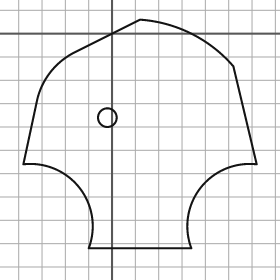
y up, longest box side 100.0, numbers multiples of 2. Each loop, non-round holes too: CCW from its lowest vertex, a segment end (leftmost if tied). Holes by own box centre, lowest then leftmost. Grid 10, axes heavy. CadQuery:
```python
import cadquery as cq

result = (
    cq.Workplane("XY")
    .moveTo(-10.0, -92.0)
    .lineTo(34.0, -92.0)
    .threePointArc((38.0, -66.0), (62.0, -56.0))
    .lineTo(52.0, -14.0)
    .threePointArc((34.0, 0.0), (12.0, 6.0))
    .lineTo(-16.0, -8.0)
    .threePointArc((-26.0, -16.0), (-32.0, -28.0))
    .lineTo(-38.0, -56.0)
    .threePointArc((-14.0, -66.0), (-10.0, -92.0))
    .close()
    .moveTo(-2.0, -36.0)
    .circle(4.0)
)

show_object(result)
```